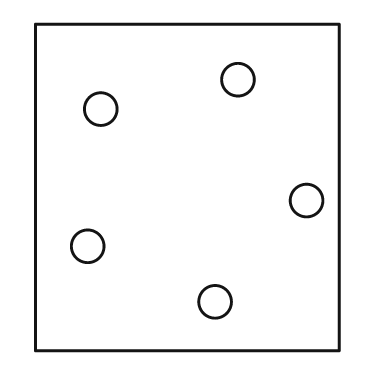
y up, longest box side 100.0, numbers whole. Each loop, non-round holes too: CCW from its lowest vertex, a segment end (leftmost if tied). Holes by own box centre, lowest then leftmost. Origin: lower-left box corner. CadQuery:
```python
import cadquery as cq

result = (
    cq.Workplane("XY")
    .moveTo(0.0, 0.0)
    .lineTo(93.0, 0.0)
    .lineTo(93.0, 100.0)
    .lineTo(0.0, 100.0)
    .close()
    .moveTo(55.0, 15.0)
    .circle(5.0)
    .moveTo(16.0, 32.0)
    .circle(5.0)
    .moveTo(83.0, 46.0)
    .circle(5.0)
    .moveTo(20.0, 74.0)
    .circle(5.0)
    .moveTo(62.0, 83.0)
    .circle(5.0)
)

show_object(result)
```